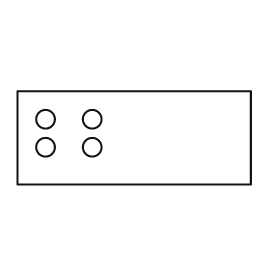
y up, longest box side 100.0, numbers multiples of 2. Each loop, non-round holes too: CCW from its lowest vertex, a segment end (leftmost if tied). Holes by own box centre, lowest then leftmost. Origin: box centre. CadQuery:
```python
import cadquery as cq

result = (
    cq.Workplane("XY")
    .moveTo(-50.0, -20.0)
    .lineTo(50.0, -20.0)
    .lineTo(50.0, 20.0)
    .lineTo(-50.0, 20.0)
    .close()
    .moveTo(-38.0, -4.0)
    .circle(4.0)
    .moveTo(-18.0, -4.0)
    .circle(4.0)
    .moveTo(-38.0, 8.0)
    .circle(4.0)
    .moveTo(-18.0, 8.0)
    .circle(4.0)
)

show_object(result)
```